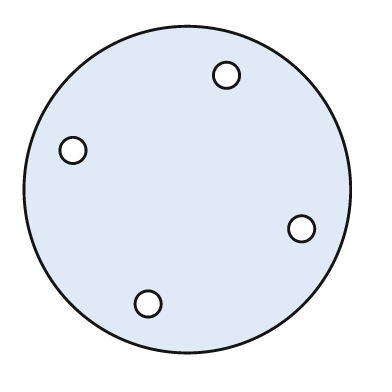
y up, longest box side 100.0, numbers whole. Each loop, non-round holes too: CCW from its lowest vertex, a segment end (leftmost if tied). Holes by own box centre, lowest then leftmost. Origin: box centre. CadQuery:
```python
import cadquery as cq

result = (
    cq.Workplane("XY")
    .moveTo(0.0, 0.0)
    .circle(50.0)
    .moveTo(-12.0, -35.0)
    .circle(4.0)
    .moveTo(35.0, -12.0)
    .circle(4.0)
    .moveTo(-35.0, 12.0)
    .circle(4.0)
    .moveTo(12.0, 35.0)
    .circle(4.0)
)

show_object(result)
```